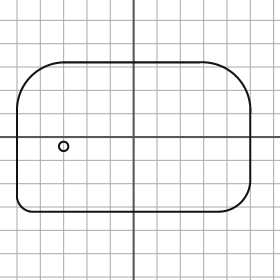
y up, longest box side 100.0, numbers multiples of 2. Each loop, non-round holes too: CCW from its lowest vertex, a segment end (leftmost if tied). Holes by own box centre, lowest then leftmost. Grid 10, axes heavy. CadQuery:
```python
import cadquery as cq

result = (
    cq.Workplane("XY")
    .moveTo(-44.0, -32.0)
    .lineTo(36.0, -32.0)
    .threePointArc((46.0, -28.0), (50.0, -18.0))
    .lineTo(50.0, 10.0)
    .threePointArc((44.0, 26.0), (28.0, 32.0))
    .lineTo(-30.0, 32.0)
    .threePointArc((-44.0, 26.0), (-50.0, 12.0))
    .lineTo(-50.0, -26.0)
    .threePointArc((-48.0, -30.0), (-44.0, -32.0))
    .close()
    .moveTo(-30.0, -4.0)
    .circle(2.0)
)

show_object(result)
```